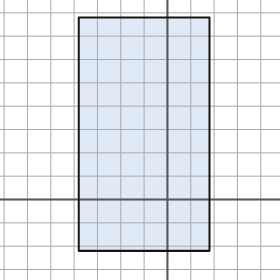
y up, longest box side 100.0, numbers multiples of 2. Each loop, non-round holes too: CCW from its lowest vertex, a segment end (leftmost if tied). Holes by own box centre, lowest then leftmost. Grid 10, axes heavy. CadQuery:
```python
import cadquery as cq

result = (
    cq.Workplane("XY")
    .moveTo(-38.0, -22.0)
    .lineTo(18.0, -22.0)
    .lineTo(18.0, 78.0)
    .lineTo(-38.0, 78.0)
    .close()
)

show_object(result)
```